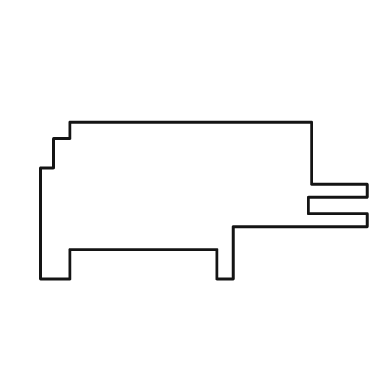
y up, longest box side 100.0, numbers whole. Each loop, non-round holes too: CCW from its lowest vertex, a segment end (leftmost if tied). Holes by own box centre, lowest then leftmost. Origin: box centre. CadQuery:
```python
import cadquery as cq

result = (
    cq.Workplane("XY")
    .moveTo(-50.0, -24.0)
    .lineTo(-41.0, -24.0)
    .lineTo(-41.0, -15.0)
    .lineTo(4.0, -15.0)
    .lineTo(4.0, -24.0)
    .lineTo(9.0, -24.0)
    .lineTo(9.0, -8.0)
    .lineTo(50.0, -8.0)
    .lineTo(50.0, -4.0)
    .lineTo(32.0, -4.0)
    .lineTo(32.0, 1.0)
    .lineTo(50.0, 1.0)
    .lineTo(50.0, 5.0)
    .lineTo(33.0, 5.0)
    .lineTo(33.0, 24.0)
    .lineTo(-41.0, 24.0)
    .lineTo(-41.0, 19.0)
    .lineTo(-46.0, 19.0)
    .lineTo(-46.0, 10.0)
    .lineTo(-50.0, 10.0)
    .close()
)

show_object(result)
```